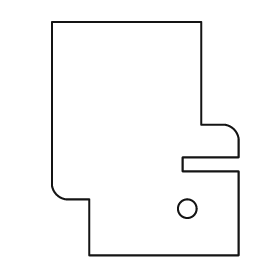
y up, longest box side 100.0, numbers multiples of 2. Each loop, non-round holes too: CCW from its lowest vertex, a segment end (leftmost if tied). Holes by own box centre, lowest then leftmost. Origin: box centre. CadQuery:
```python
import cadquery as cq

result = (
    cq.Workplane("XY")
    .moveTo(-24.0, -50.0)
    .lineTo(40.0, -50.0)
    .lineTo(40.0, -14.0)
    .lineTo(16.0, -14.0)
    .lineTo(16.0, -8.0)
    .lineTo(40.0, -8.0)
    .lineTo(40.0, 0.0)
    .threePointArc((38.0, 4.0), (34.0, 6.0))
    .lineTo(24.0, 6.0)
    .lineTo(24.0, 50.0)
    .lineTo(-40.0, 50.0)
    .lineTo(-40.0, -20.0)
    .threePointArc((-38.0, -24.0), (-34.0, -26.0))
    .lineTo(-24.0, -26.0)
    .close()
    .moveTo(18.0, -30.0)
    .circle(4.0)
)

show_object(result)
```